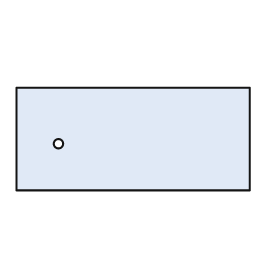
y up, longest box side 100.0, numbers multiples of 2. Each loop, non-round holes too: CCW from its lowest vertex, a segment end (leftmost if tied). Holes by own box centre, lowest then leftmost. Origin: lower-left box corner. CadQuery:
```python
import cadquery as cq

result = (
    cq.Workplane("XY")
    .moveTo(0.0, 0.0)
    .lineTo(100.0, 0.0)
    .lineTo(100.0, 44.0)
    .lineTo(0.0, 44.0)
    .close()
    .moveTo(18.0, 20.0)
    .circle(2.0)
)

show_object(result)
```